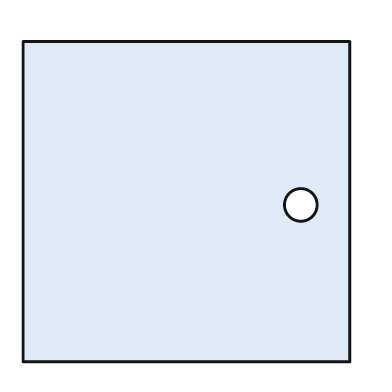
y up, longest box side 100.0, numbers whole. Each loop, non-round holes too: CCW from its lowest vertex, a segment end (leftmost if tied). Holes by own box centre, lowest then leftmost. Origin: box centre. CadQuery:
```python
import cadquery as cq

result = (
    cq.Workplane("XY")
    .moveTo(-50.0, -49.0)
    .lineTo(50.0, -49.0)
    .lineTo(50.0, 49.0)
    .lineTo(-50.0, 49.0)
    .close()
    .moveTo(35.0, -1.0)
    .circle(5.0)
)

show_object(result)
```